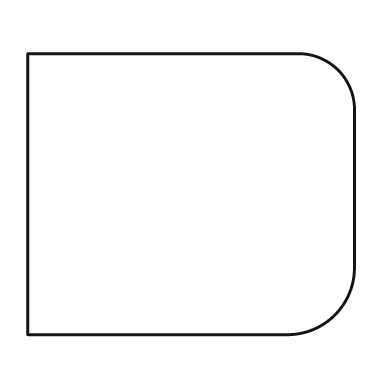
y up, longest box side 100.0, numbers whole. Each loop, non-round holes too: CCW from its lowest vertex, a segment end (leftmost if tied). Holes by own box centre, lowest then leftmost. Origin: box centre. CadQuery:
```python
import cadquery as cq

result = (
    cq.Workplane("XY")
    .moveTo(-50.0, -43.0)
    .lineTo(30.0, -43.0)
    .threePointArc((44.0, -37.0), (50.0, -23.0))
    .lineTo(50.0, 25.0)
    .threePointArc((45.0, 38.0), (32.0, 43.0))
    .lineTo(-50.0, 43.0)
    .close()
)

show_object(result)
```